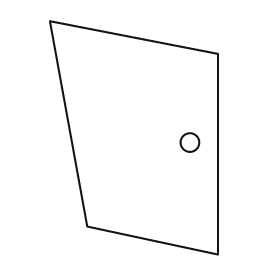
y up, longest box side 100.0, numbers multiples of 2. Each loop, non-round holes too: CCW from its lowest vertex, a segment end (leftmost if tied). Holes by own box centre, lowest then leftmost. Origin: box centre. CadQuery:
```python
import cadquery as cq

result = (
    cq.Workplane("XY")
    .moveTo(36.0, -50.0)
    .lineTo(36.0, 36.0)
    .lineTo(-36.0, 50.0)
    .lineTo(-20.0, -38.0)
    .close()
    .moveTo(24.0, -2.0)
    .circle(4.0)
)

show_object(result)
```